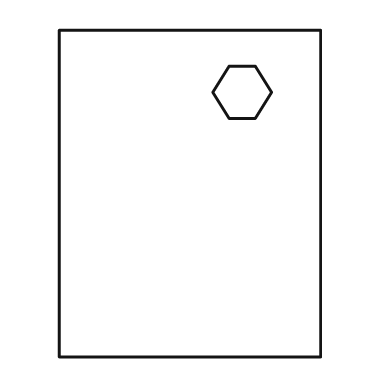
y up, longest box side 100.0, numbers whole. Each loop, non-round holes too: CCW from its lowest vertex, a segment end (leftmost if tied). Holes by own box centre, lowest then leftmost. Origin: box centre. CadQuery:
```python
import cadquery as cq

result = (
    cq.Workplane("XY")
    .moveTo(-40.0, -50.0)
    .lineTo(40.0, -50.0)
    .lineTo(40.0, 50.0)
    .lineTo(-40.0, 50.0)
    .close()
    .moveTo(12.0, 23.0)
    .lineTo(20.0, 23.0)
    .lineTo(25.0, 31.0)
    .lineTo(20.0, 39.0)
    .lineTo(12.0, 39.0)
    .lineTo(7.0, 31.0)
    .close()
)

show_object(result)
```